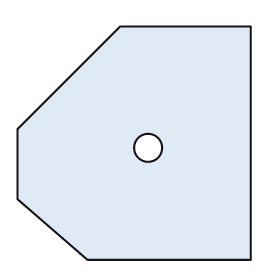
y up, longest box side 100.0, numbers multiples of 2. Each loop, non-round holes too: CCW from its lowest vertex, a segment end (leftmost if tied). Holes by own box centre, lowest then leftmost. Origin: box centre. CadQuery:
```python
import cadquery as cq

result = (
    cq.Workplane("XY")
    .moveTo(-20.0, -50.0)
    .lineTo(50.0, -50.0)
    .lineTo(50.0, 50.0)
    .lineTo(-6.0, 50.0)
    .lineTo(-50.0, 6.0)
    .lineTo(-50.0, -24.0)
    .close()
    .moveTo(6.0, -2.0)
    .circle(6.0)
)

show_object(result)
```